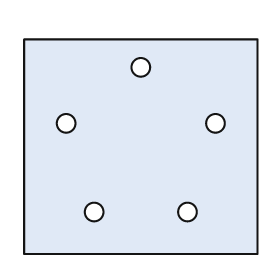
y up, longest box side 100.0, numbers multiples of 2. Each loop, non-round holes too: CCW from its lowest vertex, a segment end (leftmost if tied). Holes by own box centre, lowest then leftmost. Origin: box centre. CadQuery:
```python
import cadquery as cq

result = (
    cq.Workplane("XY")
    .moveTo(-50.0, -46.0)
    .lineTo(50.0, -46.0)
    .lineTo(50.0, 46.0)
    .lineTo(-50.0, 46.0)
    .close()
    .moveTo(-20.0, -28.0)
    .circle(4.0)
    .moveTo(20.0, -28.0)
    .circle(4.0)
    .moveTo(-32.0, 10.0)
    .circle(4.0)
    .moveTo(32.0, 10.0)
    .circle(4.0)
    .moveTo(0.0, 34.0)
    .circle(4.0)
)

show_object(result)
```